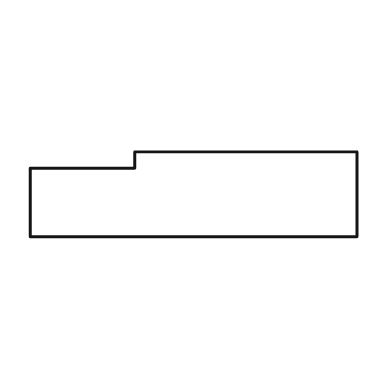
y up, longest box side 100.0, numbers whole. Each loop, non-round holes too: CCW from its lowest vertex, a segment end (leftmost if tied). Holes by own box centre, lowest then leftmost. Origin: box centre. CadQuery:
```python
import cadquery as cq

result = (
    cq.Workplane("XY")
    .moveTo(-50.0, -13.0)
    .lineTo(50.0, -13.0)
    .lineTo(50.0, 13.0)
    .lineTo(-18.0, 13.0)
    .lineTo(-18.0, 8.0)
    .lineTo(-50.0, 8.0)
    .close()
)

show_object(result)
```